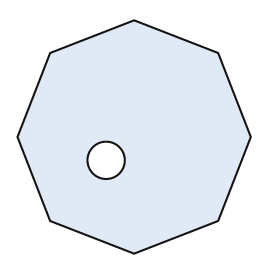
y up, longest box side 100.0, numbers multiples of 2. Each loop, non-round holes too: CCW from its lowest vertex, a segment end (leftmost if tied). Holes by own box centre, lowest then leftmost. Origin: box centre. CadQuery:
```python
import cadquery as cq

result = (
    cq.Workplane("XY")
    .moveTo(0.0, -50.0)
    .lineTo(36.0, -36.0)
    .lineTo(50.0, 0.0)
    .lineTo(36.0, 36.0)
    .lineTo(0.0, 50.0)
    .lineTo(-36.0, 36.0)
    .lineTo(-50.0, 0.0)
    .lineTo(-36.0, -36.0)
    .close()
    .moveTo(-12.0, -10.0)
    .circle(8.0)
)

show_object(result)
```